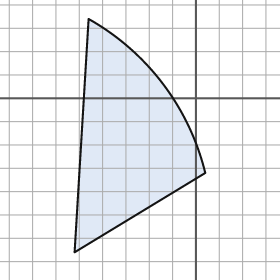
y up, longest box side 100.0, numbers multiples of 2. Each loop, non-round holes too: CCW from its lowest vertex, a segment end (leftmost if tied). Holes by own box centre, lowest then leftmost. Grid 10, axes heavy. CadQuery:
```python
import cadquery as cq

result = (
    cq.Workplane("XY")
    .moveTo(-52.0, -66.0)
    .lineTo(4.0, -32.0)
    .threePointArc((-14.0, 6.0), (-46.0, 34.0))
    .close()
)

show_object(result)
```